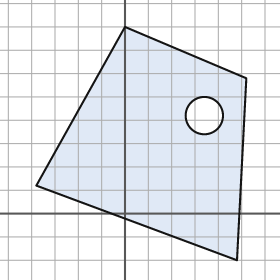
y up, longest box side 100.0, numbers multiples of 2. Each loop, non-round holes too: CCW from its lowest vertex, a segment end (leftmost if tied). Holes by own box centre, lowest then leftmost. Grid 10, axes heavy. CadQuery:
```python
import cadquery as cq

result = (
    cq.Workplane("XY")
    .moveTo(48.0, -20.0)
    .lineTo(52.0, 58.0)
    .lineTo(0.0, 80.0)
    .lineTo(-38.0, 12.0)
    .close()
    .moveTo(34.0, 42.0)
    .circle(8.0)
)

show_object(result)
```